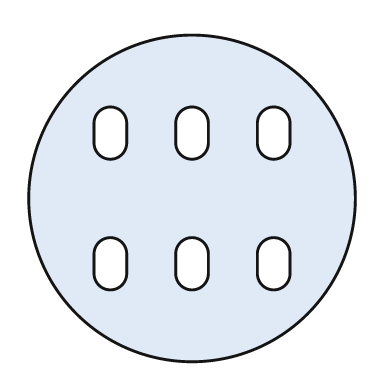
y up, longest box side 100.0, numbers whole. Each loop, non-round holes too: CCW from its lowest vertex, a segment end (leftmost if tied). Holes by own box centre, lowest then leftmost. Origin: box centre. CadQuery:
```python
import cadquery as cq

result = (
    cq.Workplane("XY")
    .moveTo(0.0, 0.0)
    .circle(50.0)
    .moveTo(-30.0, -23.0)
    .threePointArc((-25.0, -28.0), (-20.0, -23.0))
    .lineTo(-20.0, -17.0)
    .threePointArc((-25.0, -12.0), (-30.0, -17.0))
    .close()
    .moveTo(-5.0, -23.0)
    .threePointArc((0.0, -28.0), (5.0, -23.0))
    .lineTo(5.0, -17.0)
    .threePointArc((0.0, -12.0), (-5.0, -17.0))
    .close()
    .moveTo(20.0, -23.0)
    .threePointArc((25.0, -28.0), (30.0, -23.0))
    .lineTo(30.0, -17.0)
    .threePointArc((25.0, -12.0), (20.0, -17.0))
    .close()
    .moveTo(-30.0, 17.0)
    .threePointArc((-25.0, 12.0), (-20.0, 17.0))
    .lineTo(-20.0, 23.0)
    .threePointArc((-25.0, 28.0), (-30.0, 23.0))
    .close()
    .moveTo(-5.0, 17.0)
    .threePointArc((0.0, 12.0), (5.0, 17.0))
    .lineTo(5.0, 23.0)
    .threePointArc((0.0, 28.0), (-5.0, 23.0))
    .close()
    .moveTo(20.0, 17.0)
    .threePointArc((25.0, 12.0), (30.0, 17.0))
    .lineTo(30.0, 23.0)
    .threePointArc((25.0, 28.0), (20.0, 23.0))
    .close()
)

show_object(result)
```